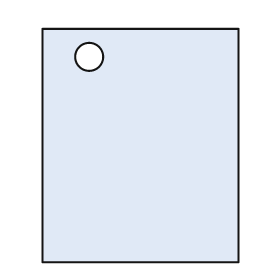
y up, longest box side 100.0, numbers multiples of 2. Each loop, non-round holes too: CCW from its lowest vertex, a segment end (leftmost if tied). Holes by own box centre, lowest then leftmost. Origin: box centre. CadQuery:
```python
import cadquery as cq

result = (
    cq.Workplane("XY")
    .moveTo(-42.0, -50.0)
    .lineTo(42.0, -50.0)
    .lineTo(42.0, 50.0)
    .lineTo(-42.0, 50.0)
    .close()
    .moveTo(-22.0, 38.0)
    .circle(6.0)
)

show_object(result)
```